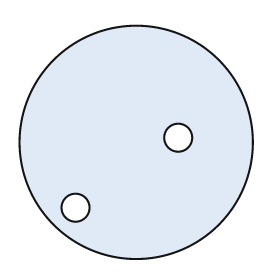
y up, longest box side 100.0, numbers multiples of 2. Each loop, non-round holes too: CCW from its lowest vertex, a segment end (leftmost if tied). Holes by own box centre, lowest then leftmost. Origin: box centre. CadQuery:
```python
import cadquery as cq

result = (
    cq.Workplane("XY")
    .moveTo(0.0, 0.0)
    .circle(50.0)
    .moveTo(-26.0, -28.0)
    .circle(6.0)
    .moveTo(18.0, 2.0)
    .circle(6.0)
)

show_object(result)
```